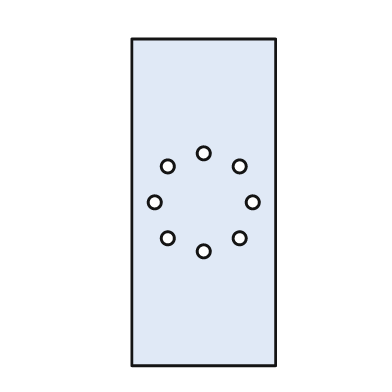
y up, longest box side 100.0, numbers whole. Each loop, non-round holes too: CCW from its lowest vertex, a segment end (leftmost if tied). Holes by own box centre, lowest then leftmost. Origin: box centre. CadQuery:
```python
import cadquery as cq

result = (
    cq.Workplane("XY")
    .moveTo(-22.0, -50.0)
    .lineTo(22.0, -50.0)
    .lineTo(22.0, 50.0)
    .lineTo(-22.0, 50.0)
    .close()
    .moveTo(0.0, -15.0)
    .circle(2.0)
    .moveTo(-11.0, -11.0)
    .circle(2.0)
    .moveTo(11.0, -11.0)
    .circle(2.0)
    .moveTo(-15.0, 0.0)
    .circle(2.0)
    .moveTo(15.0, 0.0)
    .circle(2.0)
    .moveTo(-11.0, 11.0)
    .circle(2.0)
    .moveTo(11.0, 11.0)
    .circle(2.0)
    .moveTo(0.0, 15.0)
    .circle(2.0)
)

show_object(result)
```